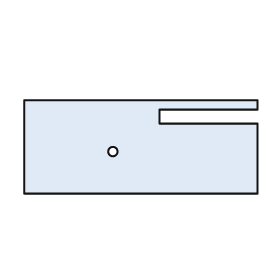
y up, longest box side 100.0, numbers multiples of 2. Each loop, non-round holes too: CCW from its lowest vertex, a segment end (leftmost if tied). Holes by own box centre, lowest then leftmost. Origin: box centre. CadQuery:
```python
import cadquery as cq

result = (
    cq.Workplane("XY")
    .moveTo(-50.0, -20.0)
    .lineTo(50.0, -20.0)
    .lineTo(50.0, 10.0)
    .lineTo(8.0, 10.0)
    .lineTo(8.0, 16.0)
    .lineTo(50.0, 16.0)
    .lineTo(50.0, 20.0)
    .lineTo(-50.0, 20.0)
    .close()
    .moveTo(-12.0, -2.0)
    .circle(2.0)
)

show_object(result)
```